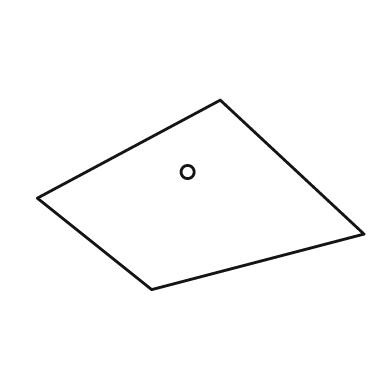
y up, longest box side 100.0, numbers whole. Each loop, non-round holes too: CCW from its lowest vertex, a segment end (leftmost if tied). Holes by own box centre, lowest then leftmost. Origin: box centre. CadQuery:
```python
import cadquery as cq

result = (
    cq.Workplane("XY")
    .moveTo(-15.0, -29.0)
    .lineTo(50.0, -12.0)
    .lineTo(6.0, 29.0)
    .lineTo(-50.0, -1.0)
    .close()
    .moveTo(-4.0, 7.0)
    .circle(2.0)
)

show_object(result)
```